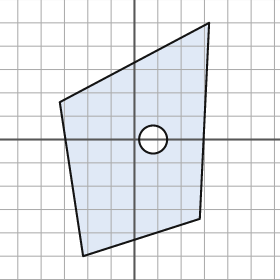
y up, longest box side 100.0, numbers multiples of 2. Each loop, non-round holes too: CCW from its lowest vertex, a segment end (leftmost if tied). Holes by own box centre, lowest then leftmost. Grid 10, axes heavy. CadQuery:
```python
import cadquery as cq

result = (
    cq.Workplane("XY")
    .moveTo(-22.0, -50.0)
    .lineTo(28.0, -34.0)
    .lineTo(32.0, 50.0)
    .lineTo(-32.0, 16.0)
    .close()
    .moveTo(8.0, 0.0)
    .circle(6.0)
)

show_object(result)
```